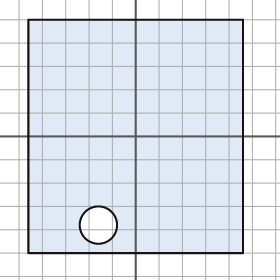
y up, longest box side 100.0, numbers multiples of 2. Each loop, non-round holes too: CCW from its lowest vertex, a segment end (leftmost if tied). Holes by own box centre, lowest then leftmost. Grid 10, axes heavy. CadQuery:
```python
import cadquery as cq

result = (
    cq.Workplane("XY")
    .moveTo(-46.0, -50.0)
    .lineTo(46.0, -50.0)
    .lineTo(46.0, 50.0)
    .lineTo(-46.0, 50.0)
    .close()
    .moveTo(-16.0, -38.0)
    .circle(8.0)
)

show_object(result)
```